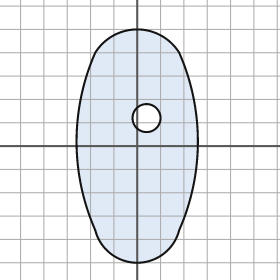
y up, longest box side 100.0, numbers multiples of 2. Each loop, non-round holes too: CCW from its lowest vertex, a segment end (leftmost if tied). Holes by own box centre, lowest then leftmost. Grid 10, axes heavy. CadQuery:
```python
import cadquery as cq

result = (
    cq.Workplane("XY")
    .moveTo(-18.0, -36.0)
    .threePointArc((0.0, -50.0), (18.0, -36.0))
    .threePointArc((26.0, 2.0), (18.0, 40.0))
    .threePointArc((0.0, 50.0), (-18.0, 40.0))
    .threePointArc((-26.0, 2.0), (-18.0, -36.0))
    .close()
    .moveTo(4.0, 12.0)
    .circle(6.0)
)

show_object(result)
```